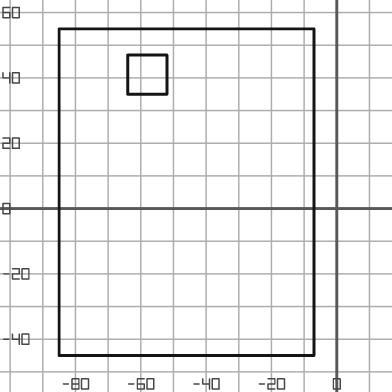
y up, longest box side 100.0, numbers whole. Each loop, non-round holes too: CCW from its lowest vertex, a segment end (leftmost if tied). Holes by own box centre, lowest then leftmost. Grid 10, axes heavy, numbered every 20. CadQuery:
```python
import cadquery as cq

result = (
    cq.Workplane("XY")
    .moveTo(-85.0, -45.0)
    .lineTo(-7.0, -45.0)
    .lineTo(-7.0, 55.0)
    .lineTo(-85.0, 55.0)
    .close()
    .moveTo(-64.0, 35.0)
    .lineTo(-52.0, 35.0)
    .lineTo(-52.0, 47.0)
    .lineTo(-64.0, 47.0)
    .close()
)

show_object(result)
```